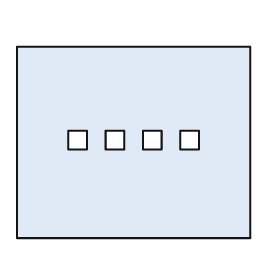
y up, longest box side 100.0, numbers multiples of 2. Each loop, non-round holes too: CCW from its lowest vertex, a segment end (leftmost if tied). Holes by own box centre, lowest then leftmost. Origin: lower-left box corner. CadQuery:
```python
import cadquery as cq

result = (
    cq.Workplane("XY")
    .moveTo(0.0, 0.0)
    .lineTo(100.0, 0.0)
    .lineTo(100.0, 82.0)
    .lineTo(0.0, 82.0)
    .close()
    .moveTo(22.0, 38.0)
    .lineTo(30.0, 38.0)
    .lineTo(30.0, 46.0)
    .lineTo(22.0, 46.0)
    .close()
    .moveTo(38.0, 38.0)
    .lineTo(46.0, 38.0)
    .lineTo(46.0, 46.0)
    .lineTo(38.0, 46.0)
    .close()
    .moveTo(54.0, 38.0)
    .lineTo(62.0, 38.0)
    .lineTo(62.0, 46.0)
    .lineTo(54.0, 46.0)
    .close()
    .moveTo(70.0, 38.0)
    .lineTo(78.0, 38.0)
    .lineTo(78.0, 46.0)
    .lineTo(70.0, 46.0)
    .close()
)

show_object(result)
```